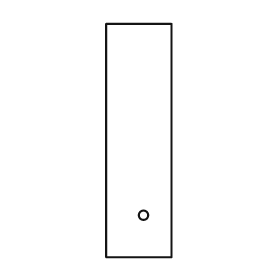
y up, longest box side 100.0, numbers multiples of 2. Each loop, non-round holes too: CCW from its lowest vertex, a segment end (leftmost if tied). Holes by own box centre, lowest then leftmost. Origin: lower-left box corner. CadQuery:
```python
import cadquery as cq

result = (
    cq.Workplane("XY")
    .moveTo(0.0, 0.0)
    .lineTo(28.0, 0.0)
    .lineTo(28.0, 100.0)
    .lineTo(0.0, 100.0)
    .close()
    .moveTo(16.0, 18.0)
    .circle(2.0)
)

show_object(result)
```